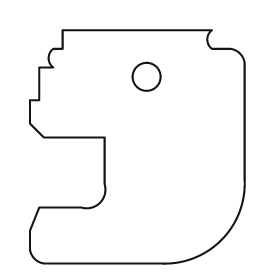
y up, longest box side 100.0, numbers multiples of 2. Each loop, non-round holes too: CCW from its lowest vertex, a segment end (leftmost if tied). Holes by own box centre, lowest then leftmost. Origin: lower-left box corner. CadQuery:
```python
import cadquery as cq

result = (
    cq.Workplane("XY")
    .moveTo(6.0, 0.0)
    .lineTo(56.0, 0.0)
    .threePointArc((82.0, 10.0), (92.0, 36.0))
    .lineTo(92.0, 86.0)
    .threePointArc((90.0, 90.0), (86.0, 92.0))
    .lineTo(78.0, 92.0)
    .threePointArc((76.0, 96.0), (78.0, 100.0))
    .lineTo(14.0, 100.0)
    .lineTo(14.0, 92.0)
    .lineTo(10.0, 92.0)
    .threePointArc((8.0, 88.0), (10.0, 84.0))
    .lineTo(4.0, 84.0)
    .lineTo(4.0, 70.0)
    .lineTo(0.0, 70.0)
    .lineTo(0.0, 60.0)
    .lineTo(6.0, 54.0)
    .lineTo(32.0, 54.0)
    .lineTo(32.0, 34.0)
    .threePointArc((30.0, 26.0), (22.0, 24.0))
    .lineTo(4.0, 24.0)
    .lineTo(0.0, 14.0)
    .lineTo(0.0, 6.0)
    .threePointArc((2.0, 2.0), (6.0, 0.0))
    .close()
    .moveTo(50.0, 80.0)
    .circle(6.0)
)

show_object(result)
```